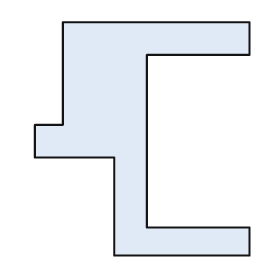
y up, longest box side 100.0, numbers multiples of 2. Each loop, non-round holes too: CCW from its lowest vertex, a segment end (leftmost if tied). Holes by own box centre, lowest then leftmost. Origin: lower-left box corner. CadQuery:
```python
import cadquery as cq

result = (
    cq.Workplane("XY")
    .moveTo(34.0, 0.0)
    .lineTo(92.0, 0.0)
    .lineTo(92.0, 12.0)
    .lineTo(48.0, 12.0)
    .lineTo(48.0, 86.0)
    .lineTo(92.0, 86.0)
    .lineTo(92.0, 100.0)
    .lineTo(12.0, 100.0)
    .lineTo(12.0, 56.0)
    .lineTo(0.0, 56.0)
    .lineTo(0.0, 42.0)
    .lineTo(34.0, 42.0)
    .close()
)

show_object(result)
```